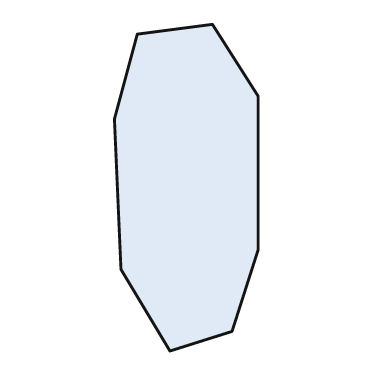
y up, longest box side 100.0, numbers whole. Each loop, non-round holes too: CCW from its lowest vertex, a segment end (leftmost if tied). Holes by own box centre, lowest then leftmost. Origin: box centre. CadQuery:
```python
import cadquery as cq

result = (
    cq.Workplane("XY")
    .moveTo(-5.0, -50.0)
    .lineTo(14.0, -44.0)
    .lineTo(22.0, -19.0)
    .lineTo(22.0, 28.0)
    .lineTo(8.0, 50.0)
    .lineTo(-15.0, 47.0)
    .lineTo(-22.0, 21.0)
    .lineTo(-20.0, -25.0)
    .close()
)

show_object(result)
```